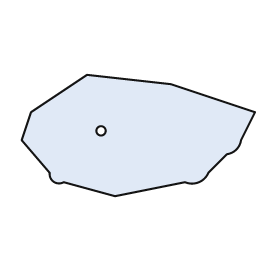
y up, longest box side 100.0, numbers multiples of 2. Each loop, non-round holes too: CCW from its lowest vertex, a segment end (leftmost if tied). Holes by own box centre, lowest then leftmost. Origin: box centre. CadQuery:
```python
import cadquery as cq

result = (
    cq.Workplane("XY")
    .moveTo(-10.0, -26.0)
    .lineTo(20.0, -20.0)
    .threePointArc((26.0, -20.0), (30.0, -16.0))
    .lineTo(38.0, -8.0)
    .threePointArc((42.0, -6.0), (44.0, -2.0))
    .lineTo(50.0, 10.0)
    .lineTo(14.0, 22.0)
    .lineTo(-22.0, 26.0)
    .lineTo(-46.0, 10.0)
    .lineTo(-50.0, -2.0)
    .lineTo(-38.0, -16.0)
    .threePointArc((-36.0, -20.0), (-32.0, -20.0))
    .close()
    .moveTo(-16.0, 2.0)
    .circle(2.0)
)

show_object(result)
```